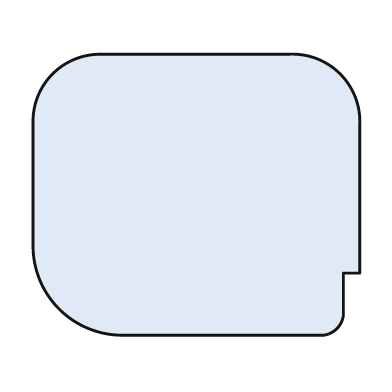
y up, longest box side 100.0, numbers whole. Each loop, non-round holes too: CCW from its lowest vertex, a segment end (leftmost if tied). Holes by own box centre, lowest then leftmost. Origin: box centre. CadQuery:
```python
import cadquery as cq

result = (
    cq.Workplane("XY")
    .moveTo(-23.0, -43.0)
    .lineTo(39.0, -43.0)
    .threePointArc((43.0, -41.0), (45.0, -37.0))
    .lineTo(45.0, -24.0)
    .lineTo(50.0, -24.0)
    .lineTo(50.0, 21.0)
    .threePointArc((44.0, 37.0), (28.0, 43.0))
    .lineTo(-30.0, 43.0)
    .threePointArc((-44.0, 37.0), (-50.0, 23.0))
    .lineTo(-50.0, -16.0)
    .threePointArc((-42.0, -35.0), (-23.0, -43.0))
    .close()
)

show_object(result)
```